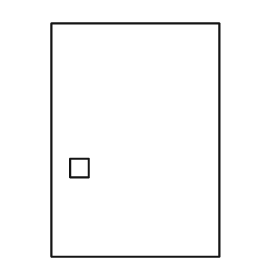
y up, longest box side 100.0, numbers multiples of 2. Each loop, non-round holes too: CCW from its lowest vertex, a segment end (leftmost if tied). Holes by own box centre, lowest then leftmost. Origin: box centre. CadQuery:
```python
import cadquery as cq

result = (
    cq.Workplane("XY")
    .moveTo(-36.0, -50.0)
    .lineTo(36.0, -50.0)
    .lineTo(36.0, 50.0)
    .lineTo(-36.0, 50.0)
    .close()
    .moveTo(-28.0, -16.0)
    .lineTo(-20.0, -16.0)
    .lineTo(-20.0, -8.0)
    .lineTo(-28.0, -8.0)
    .close()
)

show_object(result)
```